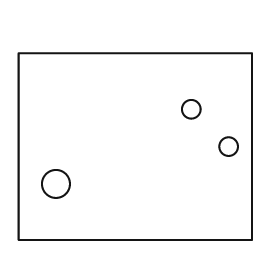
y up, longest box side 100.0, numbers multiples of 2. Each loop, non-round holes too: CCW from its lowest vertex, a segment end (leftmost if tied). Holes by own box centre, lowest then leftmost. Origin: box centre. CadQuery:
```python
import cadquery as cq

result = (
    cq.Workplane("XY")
    .moveTo(-50.0, -40.0)
    .lineTo(50.0, -40.0)
    .lineTo(50.0, 40.0)
    .lineTo(-50.0, 40.0)
    .close()
    .moveTo(-34.0, -16.0)
    .circle(6.0)
    .moveTo(40.0, 0.0)
    .circle(4.0)
    .moveTo(24.0, 16.0)
    .circle(4.0)
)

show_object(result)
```